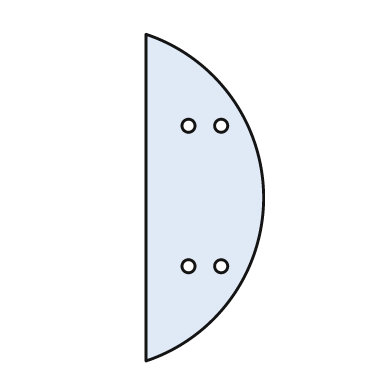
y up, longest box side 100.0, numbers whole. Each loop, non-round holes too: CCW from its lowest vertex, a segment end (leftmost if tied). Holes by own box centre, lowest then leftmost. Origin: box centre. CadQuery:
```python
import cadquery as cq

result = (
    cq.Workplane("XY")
    .moveTo(-18.0, -50.0)
    .threePointArc((18.0, 0.0), (-18.0, 50.0))
    .close()
    .moveTo(-5.0, -21.0)
    .circle(2.0)
    .moveTo(5.0, -21.0)
    .circle(2.0)
    .moveTo(-5.0, 22.0)
    .circle(2.0)
    .moveTo(5.0, 22.0)
    .circle(2.0)
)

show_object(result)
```